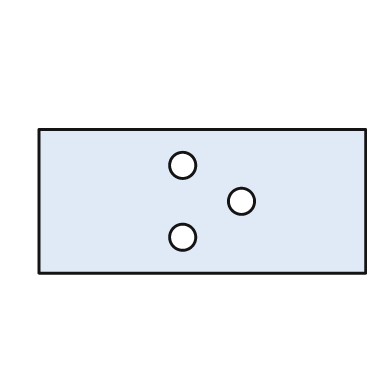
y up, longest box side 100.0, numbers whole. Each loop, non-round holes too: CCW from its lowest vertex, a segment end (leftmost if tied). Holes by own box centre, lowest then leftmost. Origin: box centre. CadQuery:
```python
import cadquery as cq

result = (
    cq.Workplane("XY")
    .moveTo(-50.0, -22.0)
    .lineTo(50.0, -22.0)
    .lineTo(50.0, 22.0)
    .lineTo(-50.0, 22.0)
    .close()
    .moveTo(-6.0, -11.0)
    .circle(4.0)
    .moveTo(12.0, 0.0)
    .circle(4.0)
    .moveTo(-6.0, 11.0)
    .circle(4.0)
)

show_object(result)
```